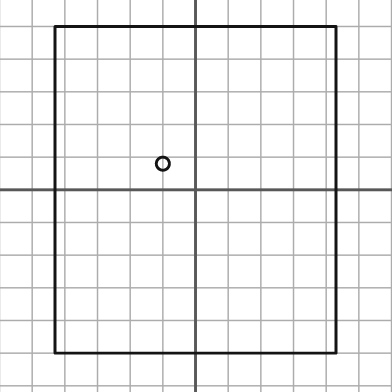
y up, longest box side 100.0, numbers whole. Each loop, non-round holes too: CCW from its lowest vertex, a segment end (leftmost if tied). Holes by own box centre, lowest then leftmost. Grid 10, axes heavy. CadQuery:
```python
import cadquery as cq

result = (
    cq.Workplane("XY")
    .moveTo(-43.0, -50.0)
    .lineTo(43.0, -50.0)
    .lineTo(43.0, 50.0)
    .lineTo(-43.0, 50.0)
    .close()
    .moveTo(-10.0, 8.0)
    .circle(2.0)
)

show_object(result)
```